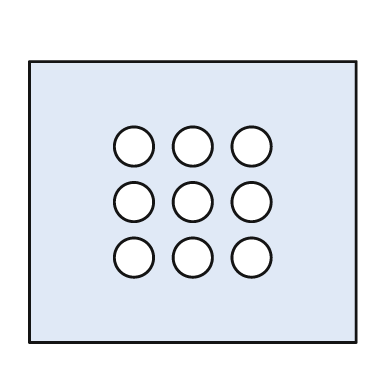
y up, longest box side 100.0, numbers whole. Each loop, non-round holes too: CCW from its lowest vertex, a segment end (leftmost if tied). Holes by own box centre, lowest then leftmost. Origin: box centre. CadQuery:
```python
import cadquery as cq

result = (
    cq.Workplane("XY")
    .moveTo(-50.0, -43.0)
    .lineTo(50.0, -43.0)
    .lineTo(50.0, 43.0)
    .lineTo(-50.0, 43.0)
    .close()
    .moveTo(-18.0, -17.0)
    .circle(6.0)
    .moveTo(0.0, -17.0)
    .circle(6.0)
    .moveTo(18.0, -17.0)
    .circle(6.0)
    .moveTo(-18.0, 0.0)
    .circle(6.0)
    .moveTo(0.0, 0.0)
    .circle(6.0)
    .moveTo(18.0, 0.0)
    .circle(6.0)
    .moveTo(-18.0, 17.0)
    .circle(6.0)
    .moveTo(0.0, 17.0)
    .circle(6.0)
    .moveTo(18.0, 17.0)
    .circle(6.0)
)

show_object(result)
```